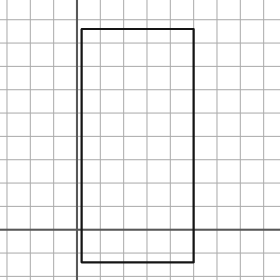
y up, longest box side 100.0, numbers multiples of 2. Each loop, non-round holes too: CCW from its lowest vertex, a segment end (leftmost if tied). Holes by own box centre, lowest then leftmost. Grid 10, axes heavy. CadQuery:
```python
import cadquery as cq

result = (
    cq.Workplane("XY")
    .moveTo(2.0, -14.0)
    .lineTo(50.0, -14.0)
    .lineTo(50.0, 86.0)
    .lineTo(2.0, 86.0)
    .close()
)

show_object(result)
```